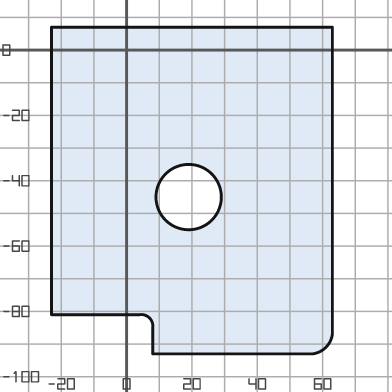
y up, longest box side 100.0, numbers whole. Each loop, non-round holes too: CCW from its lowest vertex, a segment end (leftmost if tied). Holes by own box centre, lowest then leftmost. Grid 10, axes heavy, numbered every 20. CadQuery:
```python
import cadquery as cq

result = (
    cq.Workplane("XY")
    .moveTo(8.0, -93.0)
    .lineTo(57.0, -93.0)
    .threePointArc((61.0, -91.0), (63.0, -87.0))
    .lineTo(63.0, 7.0)
    .lineTo(-23.0, 7.0)
    .lineTo(-23.0, -81.0)
    .lineTo(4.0, -81.0)
    .threePointArc((7.0, -82.0), (8.0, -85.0))
    .close()
    .moveTo(19.0, -45.0)
    .circle(10.0)
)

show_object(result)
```